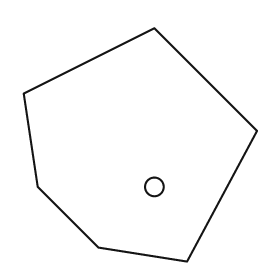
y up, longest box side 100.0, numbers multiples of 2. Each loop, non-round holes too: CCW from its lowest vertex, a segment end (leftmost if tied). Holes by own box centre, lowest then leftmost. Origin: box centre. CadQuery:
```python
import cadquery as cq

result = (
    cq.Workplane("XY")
    .moveTo(20.0, -50.0)
    .lineTo(50.0, 6.0)
    .lineTo(6.0, 50.0)
    .lineTo(-50.0, 22.0)
    .lineTo(-44.0, -18.0)
    .lineTo(-18.0, -44.0)
    .close()
    .moveTo(6.0, -18.0)
    .circle(4.0)
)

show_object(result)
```